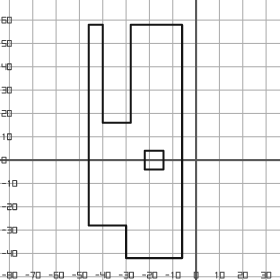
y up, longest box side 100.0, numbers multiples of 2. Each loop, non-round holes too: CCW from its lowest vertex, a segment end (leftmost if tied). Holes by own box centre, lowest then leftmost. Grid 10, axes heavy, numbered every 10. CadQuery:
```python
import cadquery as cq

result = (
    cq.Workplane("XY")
    .moveTo(-30.0, -42.0)
    .lineTo(-6.0, -42.0)
    .lineTo(-6.0, 58.0)
    .lineTo(-28.0, 58.0)
    .lineTo(-28.0, 16.0)
    .lineTo(-40.0, 16.0)
    .lineTo(-40.0, 58.0)
    .lineTo(-46.0, 58.0)
    .lineTo(-46.0, -28.0)
    .lineTo(-30.0, -28.0)
    .close()
    .moveTo(-22.0, -4.0)
    .lineTo(-14.0, -4.0)
    .lineTo(-14.0, 4.0)
    .lineTo(-22.0, 4.0)
    .close()
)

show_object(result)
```